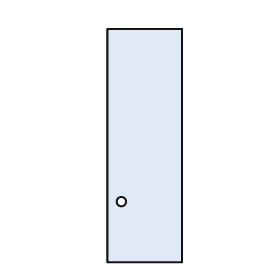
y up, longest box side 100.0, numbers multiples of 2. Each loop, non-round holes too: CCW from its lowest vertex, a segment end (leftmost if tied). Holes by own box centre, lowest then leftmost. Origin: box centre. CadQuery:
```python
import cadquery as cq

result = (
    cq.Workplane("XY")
    .moveTo(-16.0, -50.0)
    .lineTo(16.0, -50.0)
    .lineTo(16.0, 50.0)
    .lineTo(-16.0, 50.0)
    .close()
    .moveTo(-10.0, -24.0)
    .circle(2.0)
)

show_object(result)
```